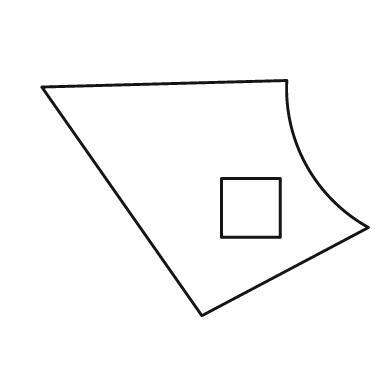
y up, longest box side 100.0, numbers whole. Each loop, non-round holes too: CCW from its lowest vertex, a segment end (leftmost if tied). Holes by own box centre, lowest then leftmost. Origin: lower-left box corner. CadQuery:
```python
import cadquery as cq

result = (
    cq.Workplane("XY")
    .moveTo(49.0, 0.0)
    .lineTo(100.0, 27.0)
    .threePointArc((81.0, 46.0), (75.0, 72.0))
    .lineTo(0.0, 70.0)
    .close()
    .moveTo(55.0, 24.0)
    .lineTo(73.0, 24.0)
    .lineTo(73.0, 42.0)
    .lineTo(55.0, 42.0)
    .close()
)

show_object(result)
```